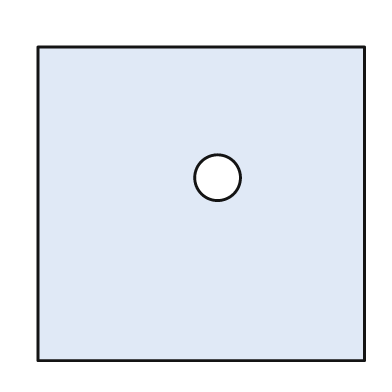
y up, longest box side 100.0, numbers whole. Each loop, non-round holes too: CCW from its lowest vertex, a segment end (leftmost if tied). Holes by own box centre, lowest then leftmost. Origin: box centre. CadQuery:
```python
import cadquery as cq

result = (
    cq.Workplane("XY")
    .moveTo(-50.0, -48.0)
    .lineTo(50.0, -48.0)
    .lineTo(50.0, 48.0)
    .lineTo(-50.0, 48.0)
    .close()
    .moveTo(5.0, 8.0)
    .circle(7.0)
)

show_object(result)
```